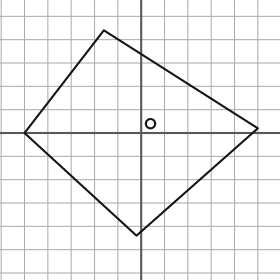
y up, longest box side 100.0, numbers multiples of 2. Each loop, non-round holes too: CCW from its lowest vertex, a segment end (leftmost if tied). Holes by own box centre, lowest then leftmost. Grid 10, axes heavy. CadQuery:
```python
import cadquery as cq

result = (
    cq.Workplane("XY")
    .moveTo(-2.0, -44.0)
    .lineTo(50.0, 2.0)
    .lineTo(-16.0, 44.0)
    .lineTo(-50.0, 0.0)
    .close()
    .moveTo(4.0, 4.0)
    .circle(2.0)
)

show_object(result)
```